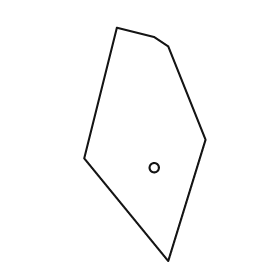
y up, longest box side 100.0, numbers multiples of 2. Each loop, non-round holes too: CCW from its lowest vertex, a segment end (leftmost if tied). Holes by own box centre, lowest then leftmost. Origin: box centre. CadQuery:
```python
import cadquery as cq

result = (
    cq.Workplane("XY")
    .moveTo(10.0, -50.0)
    .lineTo(26.0, 2.0)
    .lineTo(10.0, 42.0)
    .lineTo(4.0, 46.0)
    .lineTo(-12.0, 50.0)
    .lineTo(-26.0, -6.0)
    .close()
    .moveTo(4.0, -10.0)
    .circle(2.0)
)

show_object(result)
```